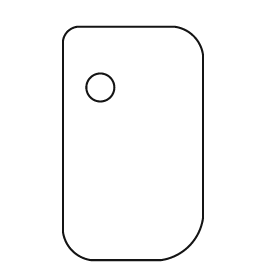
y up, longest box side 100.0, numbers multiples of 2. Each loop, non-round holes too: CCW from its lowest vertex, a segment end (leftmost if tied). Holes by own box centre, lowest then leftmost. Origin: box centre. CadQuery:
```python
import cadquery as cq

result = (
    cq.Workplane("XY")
    .moveTo(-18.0, -50.0)
    .lineTo(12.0, -50.0)
    .threePointArc((24.0, -44.0), (30.0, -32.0))
    .lineTo(30.0, 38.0)
    .threePointArc((26.0, 46.0), (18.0, 50.0))
    .lineTo(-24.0, 50.0)
    .threePointArc((-28.0, 48.0), (-30.0, 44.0))
    .lineTo(-30.0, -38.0)
    .threePointArc((-26.0, -46.0), (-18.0, -50.0))
    .close()
    .moveTo(-14.0, 24.0)
    .circle(6.0)
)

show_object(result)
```